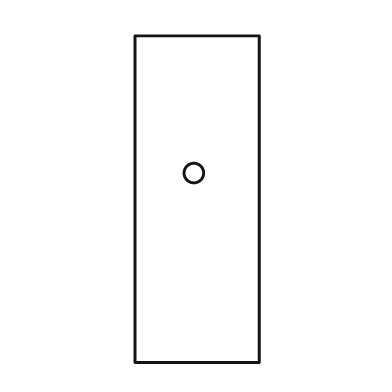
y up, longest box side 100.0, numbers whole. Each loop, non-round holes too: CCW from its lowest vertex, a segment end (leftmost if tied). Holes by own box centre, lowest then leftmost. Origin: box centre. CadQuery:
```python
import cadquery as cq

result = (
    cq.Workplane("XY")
    .moveTo(-19.0, -50.0)
    .lineTo(19.0, -50.0)
    .lineTo(19.0, 50.0)
    .lineTo(-19.0, 50.0)
    .close()
    .moveTo(-1.0, 8.0)
    .circle(3.0)
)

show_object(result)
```